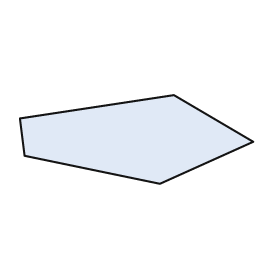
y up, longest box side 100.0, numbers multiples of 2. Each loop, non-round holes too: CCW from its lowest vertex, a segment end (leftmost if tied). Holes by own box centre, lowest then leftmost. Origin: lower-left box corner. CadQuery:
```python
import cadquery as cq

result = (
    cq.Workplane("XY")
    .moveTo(60.0, 0.0)
    .lineTo(100.0, 18.0)
    .lineTo(66.0, 38.0)
    .lineTo(0.0, 28.0)
    .lineTo(2.0, 12.0)
    .close()
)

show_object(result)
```